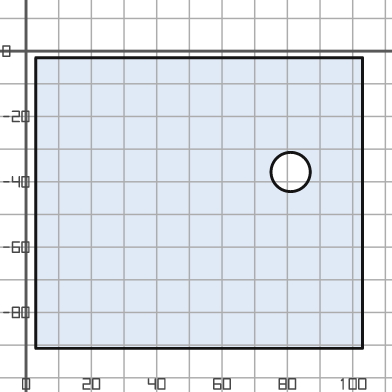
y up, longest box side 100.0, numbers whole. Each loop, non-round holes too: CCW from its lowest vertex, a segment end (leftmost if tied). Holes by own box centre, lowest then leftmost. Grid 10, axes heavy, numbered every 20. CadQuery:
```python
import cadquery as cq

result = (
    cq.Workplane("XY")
    .moveTo(3.0, -91.0)
    .lineTo(103.0, -91.0)
    .lineTo(103.0, -2.0)
    .lineTo(3.0, -2.0)
    .close()
    .moveTo(81.0, -37.0)
    .circle(6.0)
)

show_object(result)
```